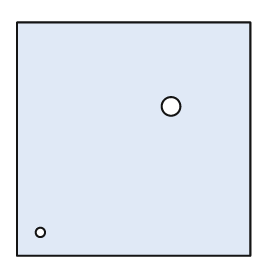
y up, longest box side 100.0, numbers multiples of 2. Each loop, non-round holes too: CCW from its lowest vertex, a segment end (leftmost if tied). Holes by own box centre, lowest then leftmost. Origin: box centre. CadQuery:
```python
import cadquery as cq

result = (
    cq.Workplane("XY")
    .moveTo(-50.0, -50.0)
    .lineTo(50.0, -50.0)
    .lineTo(50.0, 50.0)
    .lineTo(-50.0, 50.0)
    .close()
    .moveTo(-40.0, -40.0)
    .circle(2.0)
    .moveTo(16.0, 14.0)
    .circle(4.0)
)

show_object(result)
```